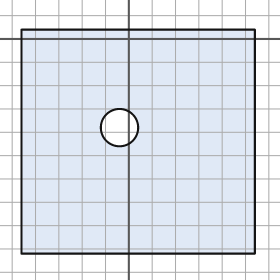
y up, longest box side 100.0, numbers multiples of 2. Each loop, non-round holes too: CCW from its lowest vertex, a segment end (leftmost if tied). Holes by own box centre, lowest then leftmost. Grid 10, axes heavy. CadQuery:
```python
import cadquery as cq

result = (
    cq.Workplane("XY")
    .moveTo(-46.0, -92.0)
    .lineTo(54.0, -92.0)
    .lineTo(54.0, 4.0)
    .lineTo(-46.0, 4.0)
    .close()
    .moveTo(-4.0, -38.0)
    .circle(8.0)
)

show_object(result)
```